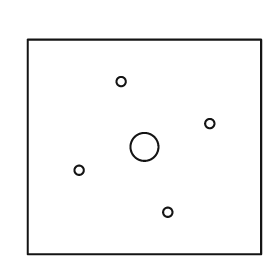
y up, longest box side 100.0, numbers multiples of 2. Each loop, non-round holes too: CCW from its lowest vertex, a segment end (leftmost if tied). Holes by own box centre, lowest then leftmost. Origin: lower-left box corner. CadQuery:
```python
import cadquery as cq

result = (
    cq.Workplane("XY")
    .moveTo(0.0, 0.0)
    .lineTo(100.0, 0.0)
    .lineTo(100.0, 92.0)
    .lineTo(0.0, 92.0)
    .close()
    .moveTo(60.0, 18.0)
    .circle(2.0)
    .moveTo(22.0, 36.0)
    .circle(2.0)
    .moveTo(50.0, 46.0)
    .circle(6.0)
    .moveTo(78.0, 56.0)
    .circle(2.0)
    .moveTo(40.0, 74.0)
    .circle(2.0)
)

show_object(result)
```